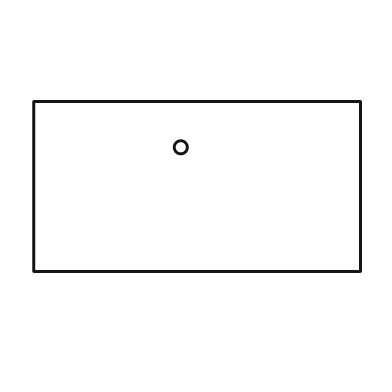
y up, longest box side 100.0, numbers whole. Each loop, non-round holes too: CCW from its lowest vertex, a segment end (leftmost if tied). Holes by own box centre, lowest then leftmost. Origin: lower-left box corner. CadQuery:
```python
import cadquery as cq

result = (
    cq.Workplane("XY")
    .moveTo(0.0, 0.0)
    .lineTo(100.0, 0.0)
    .lineTo(100.0, 52.0)
    .lineTo(0.0, 52.0)
    .close()
    .moveTo(45.0, 38.0)
    .circle(2.0)
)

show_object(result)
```